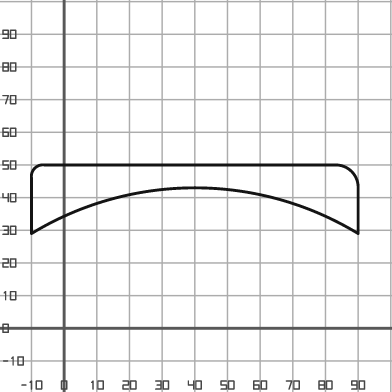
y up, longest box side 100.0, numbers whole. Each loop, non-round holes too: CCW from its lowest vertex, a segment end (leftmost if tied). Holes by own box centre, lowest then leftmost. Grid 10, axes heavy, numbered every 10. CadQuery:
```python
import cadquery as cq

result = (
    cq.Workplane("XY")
    .moveTo(-10.0, 29.0)
    .threePointArc((40.0, 43.0), (90.0, 29.0))
    .lineTo(90.0, 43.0)
    .threePointArc((88.0, 48.0), (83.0, 50.0))
    .lineTo(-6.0, 50.0)
    .threePointArc((-9.0, 49.0), (-10.0, 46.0))
    .close()
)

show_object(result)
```